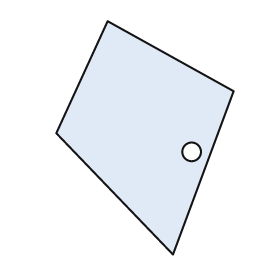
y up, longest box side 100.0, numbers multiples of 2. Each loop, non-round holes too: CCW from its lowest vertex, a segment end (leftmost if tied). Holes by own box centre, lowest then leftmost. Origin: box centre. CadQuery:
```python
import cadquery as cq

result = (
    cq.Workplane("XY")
    .moveTo(12.0, -50.0)
    .lineTo(38.0, 20.0)
    .lineTo(-16.0, 50.0)
    .lineTo(-38.0, 2.0)
    .close()
    .moveTo(20.0, -6.0)
    .circle(4.0)
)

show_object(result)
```